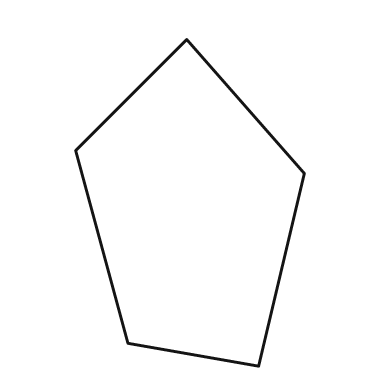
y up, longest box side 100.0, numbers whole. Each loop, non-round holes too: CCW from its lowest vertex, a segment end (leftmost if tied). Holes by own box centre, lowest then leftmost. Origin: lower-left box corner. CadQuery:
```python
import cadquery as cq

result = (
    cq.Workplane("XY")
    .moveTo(56.0, 0.0)
    .lineTo(70.0, 59.0)
    .lineTo(34.0, 100.0)
    .lineTo(0.0, 66.0)
    .lineTo(16.0, 7.0)
    .close()
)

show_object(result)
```